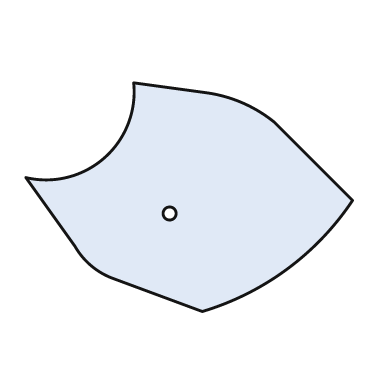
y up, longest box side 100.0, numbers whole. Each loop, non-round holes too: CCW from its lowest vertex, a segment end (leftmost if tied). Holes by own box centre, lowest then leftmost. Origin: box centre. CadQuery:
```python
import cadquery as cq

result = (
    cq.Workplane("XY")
    .moveTo(4.0, -35.0)
    .threePointArc((30.0, -22.0), (50.0, -1.0))
    .lineTo(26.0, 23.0)
    .threePointArc((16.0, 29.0), (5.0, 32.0))
    .lineTo(-17.0, 35.0)
    .threePointArc((-26.0, 12.0), (-50.0, 6.0))
    .lineTo(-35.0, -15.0)
    .threePointArc((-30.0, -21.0), (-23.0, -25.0))
    .close()
    .moveTo(-6.0, -5.0)
    .circle(2.0)
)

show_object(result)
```